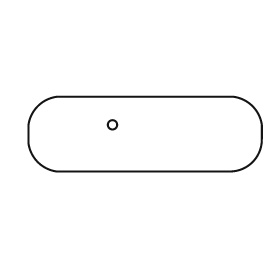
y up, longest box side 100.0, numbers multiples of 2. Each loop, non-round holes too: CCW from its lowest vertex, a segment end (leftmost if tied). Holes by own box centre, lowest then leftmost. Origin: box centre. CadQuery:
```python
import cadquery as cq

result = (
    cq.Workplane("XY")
    .moveTo(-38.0, -16.0)
    .lineTo(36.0, -16.0)
    .threePointArc((46.0, -12.0), (50.0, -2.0))
    .lineTo(50.0, 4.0)
    .threePointArc((46.0, 12.0), (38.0, 16.0))
    .lineTo(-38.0, 16.0)
    .threePointArc((-46.0, 12.0), (-50.0, 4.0))
    .lineTo(-50.0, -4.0)
    .threePointArc((-46.0, -12.0), (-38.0, -16.0))
    .close()
    .moveTo(-14.0, 4.0)
    .circle(2.0)
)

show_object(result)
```